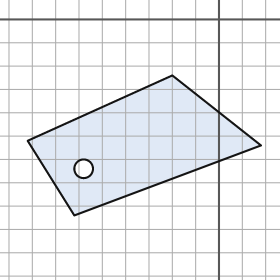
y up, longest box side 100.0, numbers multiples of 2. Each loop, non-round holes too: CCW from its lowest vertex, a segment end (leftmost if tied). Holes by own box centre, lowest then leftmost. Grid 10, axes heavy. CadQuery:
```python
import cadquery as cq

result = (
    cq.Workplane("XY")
    .moveTo(-62.0, -84.0)
    .lineTo(18.0, -54.0)
    .lineTo(-20.0, -24.0)
    .lineTo(-82.0, -52.0)
    .close()
    .moveTo(-58.0, -64.0)
    .circle(4.0)
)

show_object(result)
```